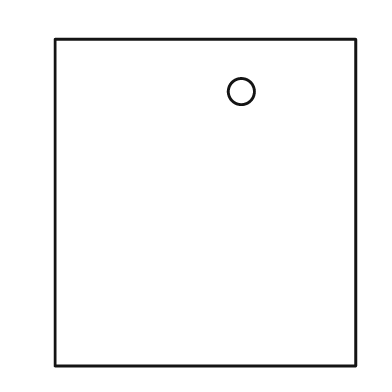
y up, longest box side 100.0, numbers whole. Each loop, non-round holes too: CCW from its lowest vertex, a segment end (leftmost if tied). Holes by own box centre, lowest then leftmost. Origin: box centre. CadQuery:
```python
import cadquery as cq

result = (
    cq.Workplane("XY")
    .moveTo(-46.0, -50.0)
    .lineTo(46.0, -50.0)
    .lineTo(46.0, 50.0)
    .lineTo(-46.0, 50.0)
    .close()
    .moveTo(11.0, 34.0)
    .circle(4.0)
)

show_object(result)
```